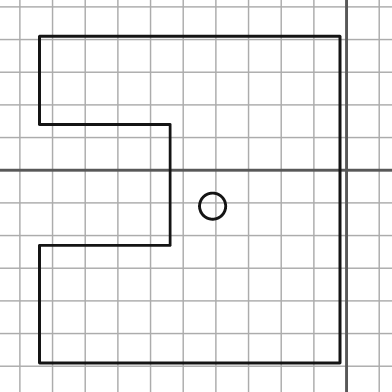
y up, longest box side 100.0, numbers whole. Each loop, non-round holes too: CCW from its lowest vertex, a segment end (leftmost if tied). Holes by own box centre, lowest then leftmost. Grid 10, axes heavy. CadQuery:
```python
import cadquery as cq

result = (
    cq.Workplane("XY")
    .moveTo(-94.0, -59.0)
    .lineTo(-2.0, -59.0)
    .lineTo(-2.0, 41.0)
    .lineTo(-94.0, 41.0)
    .lineTo(-94.0, 14.0)
    .lineTo(-54.0, 14.0)
    .lineTo(-54.0, -23.0)
    .lineTo(-94.0, -23.0)
    .close()
    .moveTo(-41.0, -11.0)
    .circle(4.0)
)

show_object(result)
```